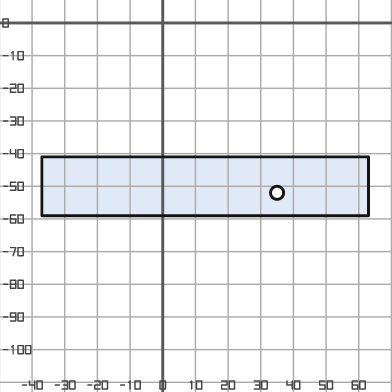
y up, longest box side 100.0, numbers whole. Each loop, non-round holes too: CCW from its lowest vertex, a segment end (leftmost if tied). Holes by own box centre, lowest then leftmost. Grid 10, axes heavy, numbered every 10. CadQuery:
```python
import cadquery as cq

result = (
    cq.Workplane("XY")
    .moveTo(-37.0, -59.0)
    .lineTo(63.0, -59.0)
    .lineTo(63.0, -41.0)
    .lineTo(-37.0, -41.0)
    .close()
    .moveTo(35.0, -52.0)
    .circle(2.0)
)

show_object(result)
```